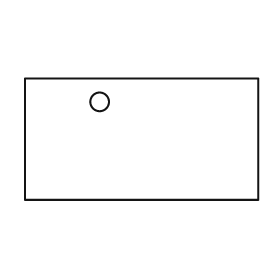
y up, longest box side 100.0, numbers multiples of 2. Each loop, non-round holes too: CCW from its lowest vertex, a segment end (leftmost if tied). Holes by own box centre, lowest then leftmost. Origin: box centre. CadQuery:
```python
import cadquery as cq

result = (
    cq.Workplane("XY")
    .moveTo(-50.0, -26.0)
    .lineTo(50.0, -26.0)
    .lineTo(50.0, 26.0)
    .lineTo(-50.0, 26.0)
    .close()
    .moveTo(-18.0, 16.0)
    .circle(4.0)
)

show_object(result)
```